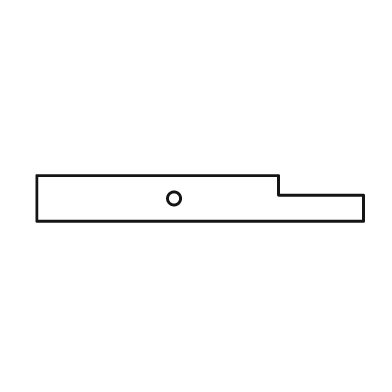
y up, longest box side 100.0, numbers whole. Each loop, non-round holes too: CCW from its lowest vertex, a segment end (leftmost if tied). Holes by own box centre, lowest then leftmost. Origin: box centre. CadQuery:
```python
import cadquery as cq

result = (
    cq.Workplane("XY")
    .moveTo(-50.0, -7.0)
    .lineTo(50.0, -7.0)
    .lineTo(50.0, 1.0)
    .lineTo(24.0, 1.0)
    .lineTo(24.0, 7.0)
    .lineTo(-50.0, 7.0)
    .close()
    .moveTo(-8.0, 0.0)
    .circle(2.0)
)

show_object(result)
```